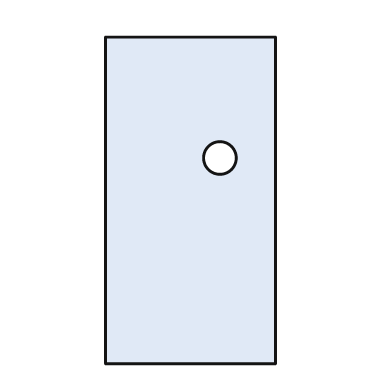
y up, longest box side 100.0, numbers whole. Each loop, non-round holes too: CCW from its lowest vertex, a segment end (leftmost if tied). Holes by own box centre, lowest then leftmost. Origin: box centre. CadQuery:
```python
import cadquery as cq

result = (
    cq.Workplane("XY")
    .moveTo(-26.0, -50.0)
    .lineTo(26.0, -50.0)
    .lineTo(26.0, 50.0)
    .lineTo(-26.0, 50.0)
    .close()
    .moveTo(9.0, 13.0)
    .circle(5.0)
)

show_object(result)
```